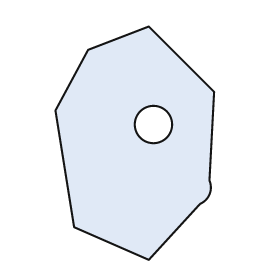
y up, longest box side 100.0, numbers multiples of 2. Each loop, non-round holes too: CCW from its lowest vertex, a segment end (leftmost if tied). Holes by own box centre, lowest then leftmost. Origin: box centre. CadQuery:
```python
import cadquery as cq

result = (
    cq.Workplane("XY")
    .moveTo(6.0, -50.0)
    .lineTo(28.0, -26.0)
    .threePointArc((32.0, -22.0), (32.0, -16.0))
    .lineTo(34.0, 22.0)
    .lineTo(6.0, 50.0)
    .lineTo(-20.0, 40.0)
    .lineTo(-34.0, 14.0)
    .lineTo(-26.0, -36.0)
    .close()
    .moveTo(8.0, 8.0)
    .circle(8.0)
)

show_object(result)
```